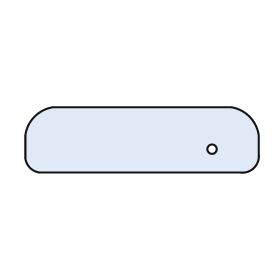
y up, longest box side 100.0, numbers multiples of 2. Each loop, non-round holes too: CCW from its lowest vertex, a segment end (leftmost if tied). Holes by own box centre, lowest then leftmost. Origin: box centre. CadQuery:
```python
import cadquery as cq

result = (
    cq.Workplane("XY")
    .moveTo(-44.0, -14.0)
    .lineTo(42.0, -14.0)
    .threePointArc((48.0, -12.0), (50.0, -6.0))
    .lineTo(50.0, 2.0)
    .threePointArc((46.0, 10.0), (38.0, 14.0))
    .lineTo(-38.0, 14.0)
    .threePointArc((-46.0, 10.0), (-50.0, 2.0))
    .lineTo(-50.0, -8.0)
    .threePointArc((-48.0, -12.0), (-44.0, -14.0))
    .close()
    .moveTo(30.0, -4.0)
    .circle(2.0)
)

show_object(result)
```